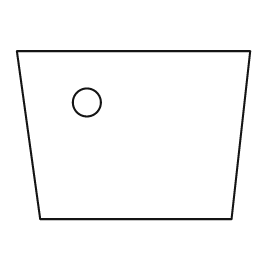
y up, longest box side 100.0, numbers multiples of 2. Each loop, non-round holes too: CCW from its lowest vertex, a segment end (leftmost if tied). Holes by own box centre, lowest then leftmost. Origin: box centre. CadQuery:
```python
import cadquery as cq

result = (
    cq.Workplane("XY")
    .moveTo(-40.0, -36.0)
    .lineTo(42.0, -36.0)
    .lineTo(50.0, 36.0)
    .lineTo(-50.0, 36.0)
    .close()
    .moveTo(-20.0, 14.0)
    .circle(6.0)
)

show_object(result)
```